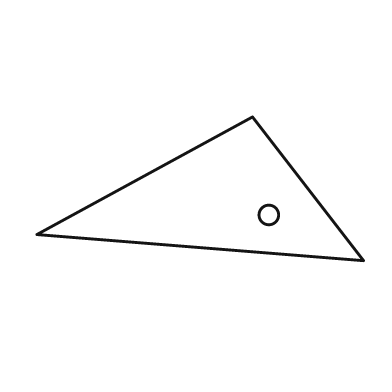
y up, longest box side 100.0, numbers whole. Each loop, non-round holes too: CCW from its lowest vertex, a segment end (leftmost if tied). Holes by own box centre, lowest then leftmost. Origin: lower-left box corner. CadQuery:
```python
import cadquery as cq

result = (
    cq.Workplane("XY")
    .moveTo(100.0, 0.0)
    .lineTo(66.0, 44.0)
    .lineTo(0.0, 8.0)
    .close()
    .moveTo(71.0, 14.0)
    .circle(3.0)
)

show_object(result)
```